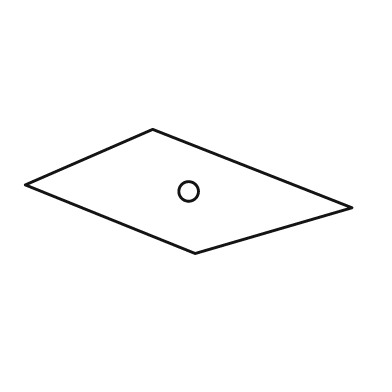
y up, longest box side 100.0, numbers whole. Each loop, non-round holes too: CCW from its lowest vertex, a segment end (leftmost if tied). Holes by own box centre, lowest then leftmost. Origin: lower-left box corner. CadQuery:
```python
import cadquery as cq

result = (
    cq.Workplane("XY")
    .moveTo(52.0, 0.0)
    .lineTo(100.0, 14.0)
    .lineTo(39.0, 38.0)
    .lineTo(0.0, 21.0)
    .close()
    .moveTo(50.0, 19.0)
    .circle(3.0)
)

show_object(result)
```